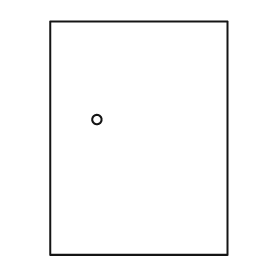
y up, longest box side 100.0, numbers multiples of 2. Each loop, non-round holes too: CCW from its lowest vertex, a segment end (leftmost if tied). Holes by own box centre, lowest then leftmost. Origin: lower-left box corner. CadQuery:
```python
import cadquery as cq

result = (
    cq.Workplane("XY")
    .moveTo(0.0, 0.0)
    .lineTo(76.0, 0.0)
    .lineTo(76.0, 100.0)
    .lineTo(0.0, 100.0)
    .close()
    .moveTo(20.0, 58.0)
    .circle(2.0)
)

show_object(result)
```